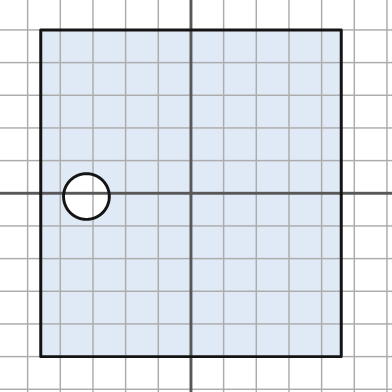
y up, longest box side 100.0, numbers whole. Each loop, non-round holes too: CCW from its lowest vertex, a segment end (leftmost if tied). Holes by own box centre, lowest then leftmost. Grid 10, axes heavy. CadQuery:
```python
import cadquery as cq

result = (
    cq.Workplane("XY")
    .moveTo(-46.0, -50.0)
    .lineTo(46.0, -50.0)
    .lineTo(46.0, 50.0)
    .lineTo(-46.0, 50.0)
    .close()
    .moveTo(-32.0, -1.0)
    .circle(7.0)
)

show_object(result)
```